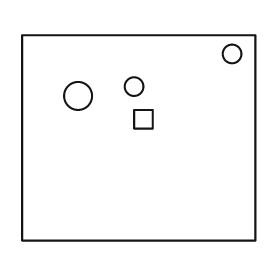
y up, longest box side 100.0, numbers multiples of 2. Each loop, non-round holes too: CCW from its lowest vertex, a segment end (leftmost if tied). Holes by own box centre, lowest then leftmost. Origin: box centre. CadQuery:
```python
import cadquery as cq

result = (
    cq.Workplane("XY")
    .moveTo(-50.0, -44.0)
    .lineTo(50.0, -44.0)
    .lineTo(50.0, 44.0)
    .lineTo(-50.0, 44.0)
    .close()
    .moveTo(-2.0, 4.0)
    .lineTo(6.0, 4.0)
    .lineTo(6.0, 12.0)
    .lineTo(-2.0, 12.0)
    .close()
    .moveTo(-26.0, 18.0)
    .circle(6.0)
    .moveTo(-2.0, 22.0)
    .circle(4.0)
    .moveTo(40.0, 36.0)
    .circle(4.0)
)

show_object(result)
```